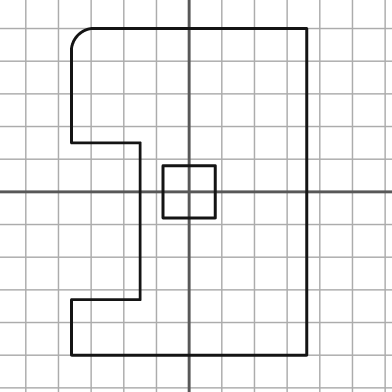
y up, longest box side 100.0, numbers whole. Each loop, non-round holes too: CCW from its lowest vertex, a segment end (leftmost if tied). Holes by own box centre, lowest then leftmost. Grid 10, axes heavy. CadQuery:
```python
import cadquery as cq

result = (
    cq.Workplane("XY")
    .moveTo(-36.0, -50.0)
    .lineTo(36.0, -50.0)
    .lineTo(36.0, 50.0)
    .lineTo(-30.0, 50.0)
    .threePointArc((-34.0, 48.0), (-36.0, 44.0))
    .lineTo(-36.0, 15.0)
    .lineTo(-15.0, 15.0)
    .lineTo(-15.0, -33.0)
    .lineTo(-36.0, -33.0)
    .close()
    .moveTo(-8.0, -8.0)
    .lineTo(8.0, -8.0)
    .lineTo(8.0, 8.0)
    .lineTo(-8.0, 8.0)
    .close()
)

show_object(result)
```